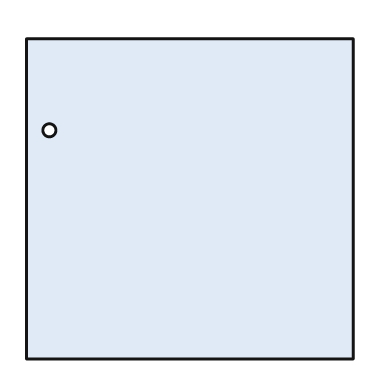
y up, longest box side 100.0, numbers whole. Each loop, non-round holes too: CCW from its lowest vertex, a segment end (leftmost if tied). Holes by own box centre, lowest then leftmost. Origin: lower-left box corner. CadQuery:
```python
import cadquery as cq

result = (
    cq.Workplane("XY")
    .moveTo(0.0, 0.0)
    .lineTo(100.0, 0.0)
    .lineTo(100.0, 98.0)
    .lineTo(0.0, 98.0)
    .close()
    .moveTo(7.0, 70.0)
    .circle(2.0)
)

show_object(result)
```